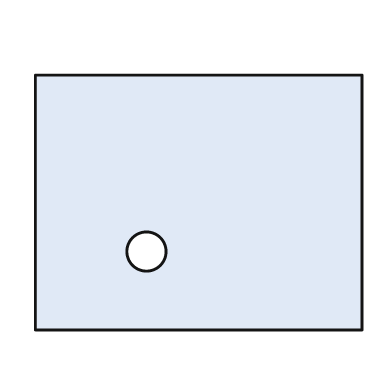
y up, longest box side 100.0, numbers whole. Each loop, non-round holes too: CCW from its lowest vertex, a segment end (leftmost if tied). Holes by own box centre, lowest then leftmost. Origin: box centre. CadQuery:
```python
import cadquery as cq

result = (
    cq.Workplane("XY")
    .moveTo(-50.0, -39.0)
    .lineTo(50.0, -39.0)
    .lineTo(50.0, 39.0)
    .lineTo(-50.0, 39.0)
    .close()
    .moveTo(-16.0, -15.0)
    .circle(6.0)
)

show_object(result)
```